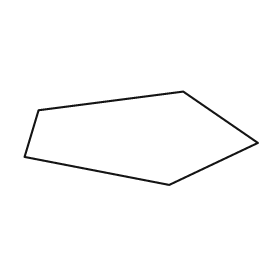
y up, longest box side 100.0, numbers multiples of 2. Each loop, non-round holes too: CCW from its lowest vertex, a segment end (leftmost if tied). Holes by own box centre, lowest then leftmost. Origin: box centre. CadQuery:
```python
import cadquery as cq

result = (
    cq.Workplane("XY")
    .moveTo(12.0, -20.0)
    .lineTo(50.0, -2.0)
    .lineTo(18.0, 20.0)
    .lineTo(-44.0, 12.0)
    .lineTo(-50.0, -8.0)
    .close()
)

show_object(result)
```